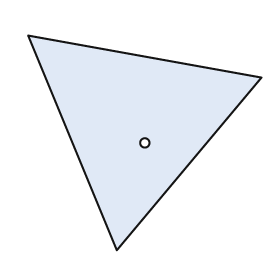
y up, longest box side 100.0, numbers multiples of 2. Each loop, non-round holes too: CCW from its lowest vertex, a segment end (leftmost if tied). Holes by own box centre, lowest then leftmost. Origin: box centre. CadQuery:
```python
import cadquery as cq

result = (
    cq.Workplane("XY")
    .moveTo(-12.0, -46.0)
    .lineTo(50.0, 28.0)
    .lineTo(-50.0, 46.0)
    .close()
    .moveTo(0.0, 0.0)
    .circle(2.0)
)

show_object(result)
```